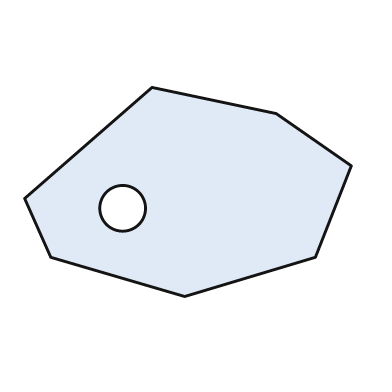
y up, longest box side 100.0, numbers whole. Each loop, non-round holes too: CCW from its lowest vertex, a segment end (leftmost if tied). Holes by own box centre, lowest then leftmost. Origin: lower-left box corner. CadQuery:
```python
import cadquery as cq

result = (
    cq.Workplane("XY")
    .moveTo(49.0, 0.0)
    .lineTo(89.0, 12.0)
    .lineTo(100.0, 40.0)
    .lineTo(77.0, 56.0)
    .lineTo(39.0, 64.0)
    .lineTo(0.0, 30.0)
    .lineTo(8.0, 12.0)
    .close()
    .moveTo(30.0, 27.0)
    .circle(7.0)
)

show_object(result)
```